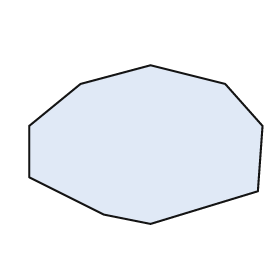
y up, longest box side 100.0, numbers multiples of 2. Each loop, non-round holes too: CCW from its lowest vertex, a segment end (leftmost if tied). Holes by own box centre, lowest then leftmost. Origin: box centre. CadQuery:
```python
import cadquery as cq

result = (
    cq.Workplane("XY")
    .moveTo(2.0, -34.0)
    .lineTo(48.0, -20.0)
    .lineTo(50.0, 8.0)
    .lineTo(34.0, 26.0)
    .lineTo(2.0, 34.0)
    .lineTo(-28.0, 26.0)
    .lineTo(-50.0, 8.0)
    .lineTo(-50.0, -14.0)
    .lineTo(-18.0, -30.0)
    .close()
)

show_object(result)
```